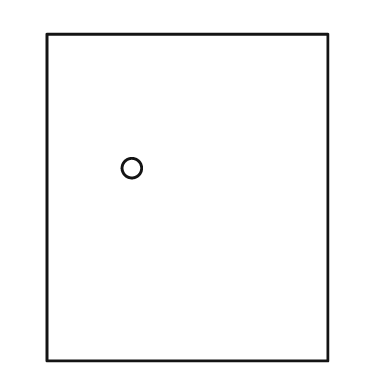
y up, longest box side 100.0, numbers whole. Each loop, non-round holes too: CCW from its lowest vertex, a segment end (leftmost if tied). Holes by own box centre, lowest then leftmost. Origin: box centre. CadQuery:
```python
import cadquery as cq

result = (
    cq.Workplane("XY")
    .moveTo(-43.0, -50.0)
    .lineTo(43.0, -50.0)
    .lineTo(43.0, 50.0)
    .lineTo(-43.0, 50.0)
    .close()
    .moveTo(-17.0, 9.0)
    .circle(3.0)
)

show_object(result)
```